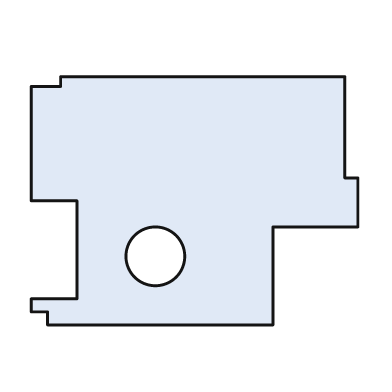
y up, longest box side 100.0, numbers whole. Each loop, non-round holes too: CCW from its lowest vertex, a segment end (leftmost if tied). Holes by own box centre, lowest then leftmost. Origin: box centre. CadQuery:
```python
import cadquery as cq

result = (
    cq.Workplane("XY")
    .moveTo(-45.0, -38.0)
    .lineTo(24.0, -38.0)
    .lineTo(24.0, -8.0)
    .lineTo(50.0, -8.0)
    .lineTo(50.0, 7.0)
    .lineTo(46.0, 7.0)
    .lineTo(46.0, 38.0)
    .lineTo(-41.0, 38.0)
    .lineTo(-41.0, 35.0)
    .lineTo(-50.0, 35.0)
    .lineTo(-50.0, 0.0)
    .lineTo(-36.0, 0.0)
    .lineTo(-36.0, -30.0)
    .lineTo(-50.0, -30.0)
    .lineTo(-50.0, -34.0)
    .lineTo(-45.0, -34.0)
    .close()
    .moveTo(-12.0, -17.0)
    .circle(9.0)
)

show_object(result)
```